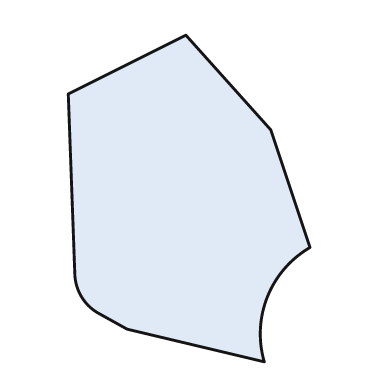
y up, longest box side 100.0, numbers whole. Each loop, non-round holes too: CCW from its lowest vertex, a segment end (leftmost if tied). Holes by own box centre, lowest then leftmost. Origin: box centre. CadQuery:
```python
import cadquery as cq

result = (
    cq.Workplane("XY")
    .moveTo(23.0, -50.0)
    .threePointArc((24.0, -30.0), (37.0, -15.0))
    .lineTo(25.0, 21.0)
    .lineTo(-1.0, 50.0)
    .lineTo(-37.0, 32.0)
    .lineTo(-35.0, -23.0)
    .threePointArc((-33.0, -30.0), (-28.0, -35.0))
    .lineTo(-19.0, -40.0)
    .close()
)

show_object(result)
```